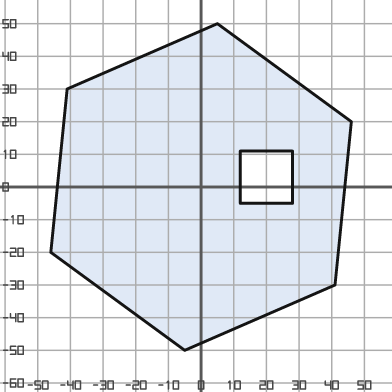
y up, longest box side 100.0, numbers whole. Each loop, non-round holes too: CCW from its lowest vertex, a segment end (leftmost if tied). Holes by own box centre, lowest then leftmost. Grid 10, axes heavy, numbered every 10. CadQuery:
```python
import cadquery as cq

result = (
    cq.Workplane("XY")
    .moveTo(-5.0, -50.0)
    .lineTo(41.0, -30.0)
    .lineTo(46.0, 20.0)
    .lineTo(5.0, 50.0)
    .lineTo(-41.0, 30.0)
    .lineTo(-46.0, -20.0)
    .close()
    .moveTo(12.0, -5.0)
    .lineTo(28.0, -5.0)
    .lineTo(28.0, 11.0)
    .lineTo(12.0, 11.0)
    .close()
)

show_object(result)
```